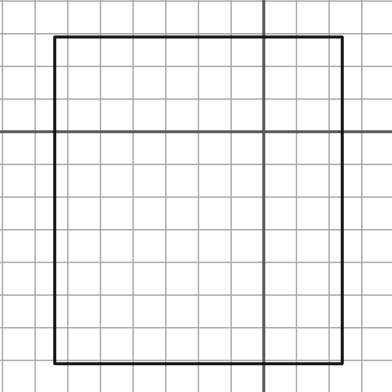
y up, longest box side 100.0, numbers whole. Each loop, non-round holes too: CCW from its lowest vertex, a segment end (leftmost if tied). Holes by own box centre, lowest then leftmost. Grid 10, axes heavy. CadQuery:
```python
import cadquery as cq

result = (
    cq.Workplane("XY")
    .moveTo(-64.0, -71.0)
    .lineTo(24.0, -71.0)
    .lineTo(24.0, 29.0)
    .lineTo(-64.0, 29.0)
    .close()
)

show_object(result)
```